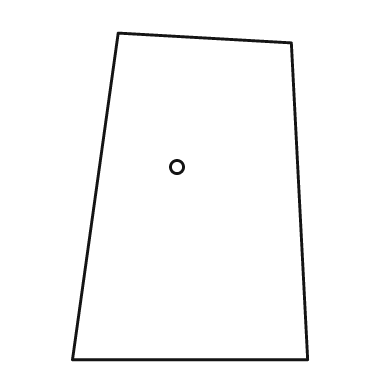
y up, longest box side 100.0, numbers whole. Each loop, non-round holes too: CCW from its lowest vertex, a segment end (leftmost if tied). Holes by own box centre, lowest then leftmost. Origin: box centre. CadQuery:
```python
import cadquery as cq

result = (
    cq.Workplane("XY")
    .moveTo(-36.0, -50.0)
    .lineTo(36.0, -50.0)
    .lineTo(31.0, 47.0)
    .lineTo(-22.0, 50.0)
    .close()
    .moveTo(-4.0, 9.0)
    .circle(2.0)
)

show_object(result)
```